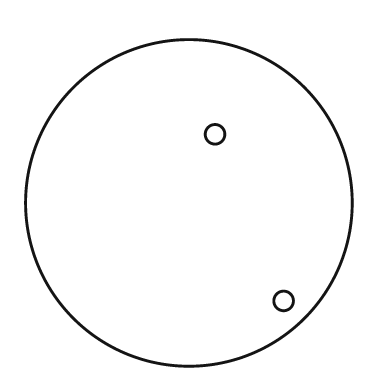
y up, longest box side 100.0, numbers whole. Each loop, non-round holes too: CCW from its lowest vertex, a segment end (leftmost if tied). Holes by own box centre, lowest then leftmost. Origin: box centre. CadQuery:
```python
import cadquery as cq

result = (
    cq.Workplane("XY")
    .moveTo(0.0, 0.0)
    .circle(50.0)
    .moveTo(29.0, -30.0)
    .circle(3.0)
    .moveTo(8.0, 21.0)
    .circle(3.0)
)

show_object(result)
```